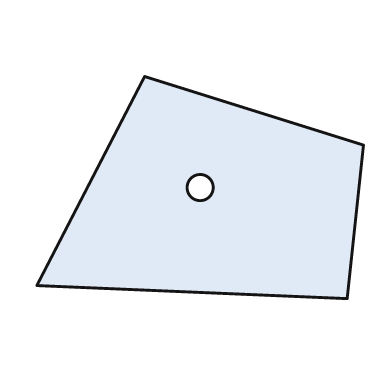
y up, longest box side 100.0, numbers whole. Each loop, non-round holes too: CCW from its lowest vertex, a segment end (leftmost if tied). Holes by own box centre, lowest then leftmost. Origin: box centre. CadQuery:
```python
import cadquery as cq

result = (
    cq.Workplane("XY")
    .moveTo(45.0, -34.0)
    .lineTo(50.0, 13.0)
    .lineTo(-17.0, 34.0)
    .lineTo(-50.0, -30.0)
    .close()
    .moveTo(0.0, 0.0)
    .circle(4.0)
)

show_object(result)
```